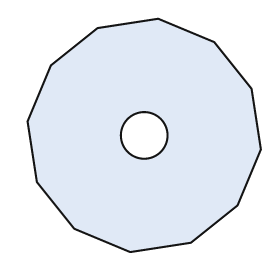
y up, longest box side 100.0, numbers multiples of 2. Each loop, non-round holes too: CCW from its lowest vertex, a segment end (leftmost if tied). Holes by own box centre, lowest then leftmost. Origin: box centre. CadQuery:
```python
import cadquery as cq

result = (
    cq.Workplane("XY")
    .moveTo(-6.0, -50.0)
    .lineTo(20.0, -46.0)
    .lineTo(40.0, -30.0)
    .lineTo(50.0, -6.0)
    .lineTo(46.0, 20.0)
    .lineTo(30.0, 40.0)
    .lineTo(6.0, 50.0)
    .lineTo(-20.0, 46.0)
    .lineTo(-40.0, 30.0)
    .lineTo(-50.0, 6.0)
    .lineTo(-46.0, -20.0)
    .lineTo(-30.0, -40.0)
    .close()
    .moveTo(0.0, 0.0)
    .circle(10.0)
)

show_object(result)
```